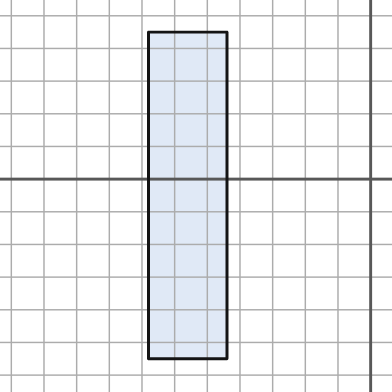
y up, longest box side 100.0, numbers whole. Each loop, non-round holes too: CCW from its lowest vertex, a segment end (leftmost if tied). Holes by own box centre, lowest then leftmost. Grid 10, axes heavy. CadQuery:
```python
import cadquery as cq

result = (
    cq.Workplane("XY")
    .moveTo(-68.0, -55.0)
    .lineTo(-44.0, -55.0)
    .lineTo(-44.0, 45.0)
    .lineTo(-68.0, 45.0)
    .close()
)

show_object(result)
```